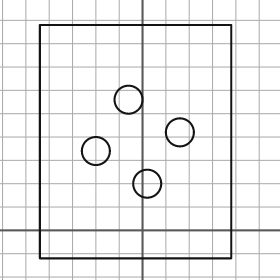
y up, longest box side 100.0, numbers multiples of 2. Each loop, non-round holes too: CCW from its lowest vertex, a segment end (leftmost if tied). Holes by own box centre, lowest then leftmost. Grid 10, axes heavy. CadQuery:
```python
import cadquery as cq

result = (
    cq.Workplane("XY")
    .moveTo(-44.0, -12.0)
    .lineTo(38.0, -12.0)
    .lineTo(38.0, 88.0)
    .lineTo(-44.0, 88.0)
    .close()
    .moveTo(2.0, 20.0)
    .circle(6.0)
    .moveTo(-20.0, 34.0)
    .circle(6.0)
    .moveTo(16.0, 42.0)
    .circle(6.0)
    .moveTo(-6.0, 56.0)
    .circle(6.0)
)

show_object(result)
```